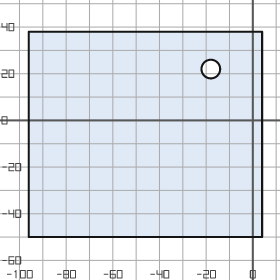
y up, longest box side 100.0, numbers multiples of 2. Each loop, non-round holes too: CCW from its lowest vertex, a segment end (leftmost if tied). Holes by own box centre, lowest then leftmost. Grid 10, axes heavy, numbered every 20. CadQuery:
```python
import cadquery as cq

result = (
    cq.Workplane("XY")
    .moveTo(-96.0, -50.0)
    .lineTo(4.0, -50.0)
    .lineTo(4.0, 38.0)
    .lineTo(-96.0, 38.0)
    .close()
    .moveTo(-18.0, 22.0)
    .circle(4.0)
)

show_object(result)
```